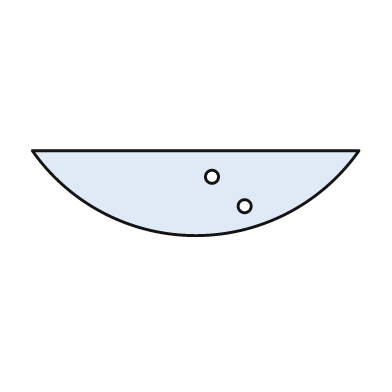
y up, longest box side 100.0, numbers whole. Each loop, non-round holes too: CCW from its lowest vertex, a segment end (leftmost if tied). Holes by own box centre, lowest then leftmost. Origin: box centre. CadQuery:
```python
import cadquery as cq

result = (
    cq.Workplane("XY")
    .moveTo(-50.0, 13.0)
    .threePointArc((0.0, -13.0), (50.0, 13.0))
    .close()
    .moveTo(15.0, -4.0)
    .circle(2.0)
    .moveTo(5.0, 5.0)
    .circle(2.0)
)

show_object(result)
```